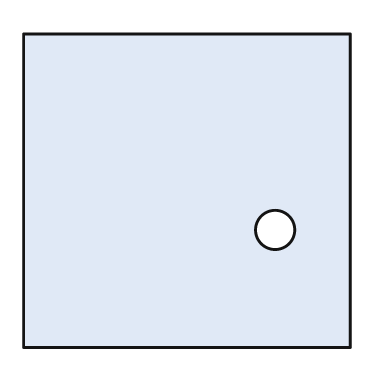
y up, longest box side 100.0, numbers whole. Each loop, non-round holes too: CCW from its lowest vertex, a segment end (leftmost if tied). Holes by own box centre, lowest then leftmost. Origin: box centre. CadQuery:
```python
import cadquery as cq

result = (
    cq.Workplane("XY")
    .moveTo(-50.0, -48.0)
    .lineTo(50.0, -48.0)
    .lineTo(50.0, 48.0)
    .lineTo(-50.0, 48.0)
    .close()
    .moveTo(27.0, -12.0)
    .circle(6.0)
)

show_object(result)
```